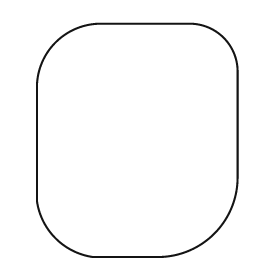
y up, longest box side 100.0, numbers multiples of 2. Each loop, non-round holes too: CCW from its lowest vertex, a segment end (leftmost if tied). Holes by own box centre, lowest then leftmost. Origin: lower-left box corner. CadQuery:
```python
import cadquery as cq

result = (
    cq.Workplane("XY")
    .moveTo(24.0, 0.0)
    .lineTo(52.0, 0.0)
    .threePointArc((76.0, 10.0), (86.0, 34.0))
    .lineTo(86.0, 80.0)
    .threePointArc((80.0, 94.0), (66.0, 100.0))
    .lineTo(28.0, 100.0)
    .threePointArc((8.0, 92.0), (0.0, 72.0))
    .lineTo(0.0, 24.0)
    .threePointArc((8.0, 8.0), (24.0, 0.0))
    .close()
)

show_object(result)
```